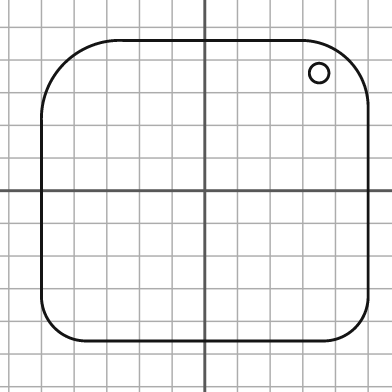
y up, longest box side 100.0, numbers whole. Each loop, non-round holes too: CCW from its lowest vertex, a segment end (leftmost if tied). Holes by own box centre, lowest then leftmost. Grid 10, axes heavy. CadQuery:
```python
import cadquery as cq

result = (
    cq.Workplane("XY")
    .moveTo(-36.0, -46.0)
    .lineTo(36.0, -46.0)
    .threePointArc((46.0, -42.0), (50.0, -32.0))
    .lineTo(50.0, 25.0)
    .threePointArc((44.0, 40.0), (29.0, 46.0))
    .lineTo(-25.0, 46.0)
    .threePointArc((-43.0, 39.0), (-50.0, 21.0))
    .lineTo(-50.0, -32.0)
    .threePointArc((-46.0, -42.0), (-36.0, -46.0))
    .close()
    .moveTo(35.0, 36.0)
    .circle(3.0)
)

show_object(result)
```